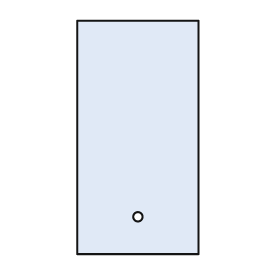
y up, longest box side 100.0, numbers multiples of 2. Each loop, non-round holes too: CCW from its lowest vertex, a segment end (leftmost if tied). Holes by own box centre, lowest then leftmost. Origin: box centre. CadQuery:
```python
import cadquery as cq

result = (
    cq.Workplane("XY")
    .moveTo(-26.0, -50.0)
    .lineTo(26.0, -50.0)
    .lineTo(26.0, 50.0)
    .lineTo(-26.0, 50.0)
    .close()
    .moveTo(0.0, -34.0)
    .circle(2.0)
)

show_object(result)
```